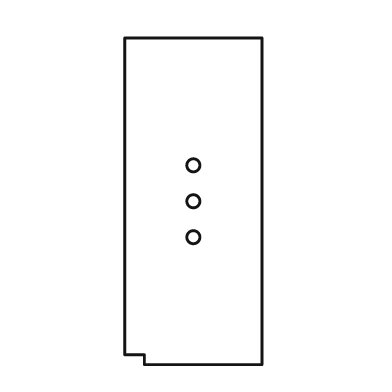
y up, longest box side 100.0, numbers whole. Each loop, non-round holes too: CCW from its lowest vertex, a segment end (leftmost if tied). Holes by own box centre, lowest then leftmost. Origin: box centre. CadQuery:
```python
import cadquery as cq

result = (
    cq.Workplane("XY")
    .moveTo(-15.0, -50.0)
    .lineTo(21.0, -50.0)
    .lineTo(21.0, 50.0)
    .lineTo(-21.0, 50.0)
    .lineTo(-21.0, -47.0)
    .lineTo(-15.0, -47.0)
    .close()
    .moveTo(0.0, -11.0)
    .circle(2.0)
    .moveTo(0.0, 0.0)
    .circle(2.0)
    .moveTo(0.0, 11.0)
    .circle(2.0)
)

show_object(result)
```